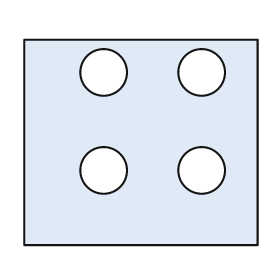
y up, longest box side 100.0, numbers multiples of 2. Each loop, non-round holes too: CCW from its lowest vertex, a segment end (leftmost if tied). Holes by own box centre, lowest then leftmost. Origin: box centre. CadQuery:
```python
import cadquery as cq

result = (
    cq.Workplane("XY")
    .moveTo(-50.0, -44.0)
    .lineTo(50.0, -44.0)
    .lineTo(50.0, 44.0)
    .lineTo(-50.0, 44.0)
    .close()
    .moveTo(-16.0, -12.0)
    .circle(10.0)
    .moveTo(26.0, -12.0)
    .circle(10.0)
    .moveTo(-16.0, 30.0)
    .circle(10.0)
    .moveTo(26.0, 30.0)
    .circle(10.0)
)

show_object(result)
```